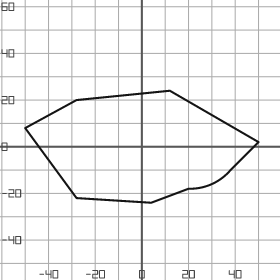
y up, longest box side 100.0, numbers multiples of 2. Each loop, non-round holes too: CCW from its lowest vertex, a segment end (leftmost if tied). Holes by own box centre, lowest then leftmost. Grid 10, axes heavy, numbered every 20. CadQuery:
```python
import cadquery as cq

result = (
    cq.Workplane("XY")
    .moveTo(4.0, -24.0)
    .lineTo(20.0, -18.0)
    .threePointArc((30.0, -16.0), (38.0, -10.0))
    .lineTo(50.0, 2.0)
    .lineTo(12.0, 24.0)
    .lineTo(-28.0, 20.0)
    .lineTo(-50.0, 8.0)
    .lineTo(-28.0, -22.0)
    .close()
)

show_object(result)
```